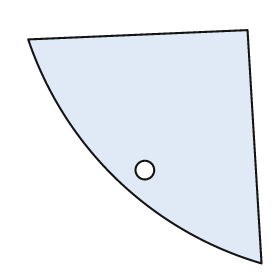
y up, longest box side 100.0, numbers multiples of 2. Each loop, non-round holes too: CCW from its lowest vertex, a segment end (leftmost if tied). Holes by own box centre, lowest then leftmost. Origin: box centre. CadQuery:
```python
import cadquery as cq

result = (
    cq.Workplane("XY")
    .moveTo(50.0, -50.0)
    .lineTo(44.0, 50.0)
    .lineTo(-50.0, 46.0)
    .threePointArc((-12.0, -14.0), (50.0, -50.0))
    .close()
    .moveTo(0.0, -10.0)
    .circle(4.0)
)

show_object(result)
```